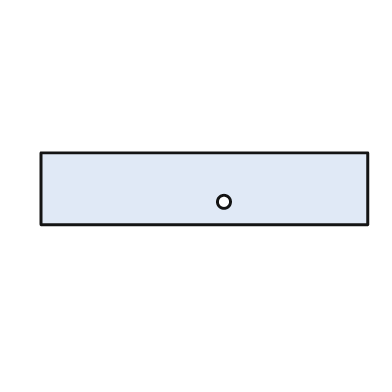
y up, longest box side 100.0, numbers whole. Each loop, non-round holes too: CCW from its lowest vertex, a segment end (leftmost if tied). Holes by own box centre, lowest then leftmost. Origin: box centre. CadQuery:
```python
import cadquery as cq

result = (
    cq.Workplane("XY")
    .moveTo(-50.0, -11.0)
    .lineTo(50.0, -11.0)
    .lineTo(50.0, 11.0)
    .lineTo(-50.0, 11.0)
    .close()
    .moveTo(6.0, -4.0)
    .circle(2.0)
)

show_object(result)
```